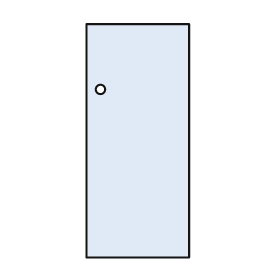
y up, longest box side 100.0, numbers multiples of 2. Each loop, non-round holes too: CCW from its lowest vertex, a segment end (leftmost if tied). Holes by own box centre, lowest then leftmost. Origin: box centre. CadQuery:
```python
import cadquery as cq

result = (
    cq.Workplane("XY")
    .moveTo(-22.0, -50.0)
    .lineTo(22.0, -50.0)
    .lineTo(22.0, 50.0)
    .lineTo(-22.0, 50.0)
    .close()
    .moveTo(-16.0, 22.0)
    .circle(2.0)
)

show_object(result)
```